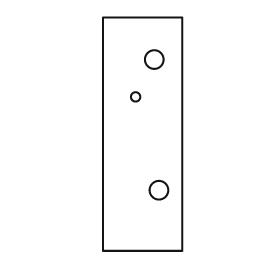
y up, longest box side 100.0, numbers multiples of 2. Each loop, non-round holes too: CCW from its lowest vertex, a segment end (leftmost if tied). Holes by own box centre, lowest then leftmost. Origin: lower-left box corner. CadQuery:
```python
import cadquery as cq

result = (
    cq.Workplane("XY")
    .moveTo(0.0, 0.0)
    .lineTo(34.0, 0.0)
    .lineTo(34.0, 100.0)
    .lineTo(0.0, 100.0)
    .close()
    .moveTo(24.0, 26.0)
    .circle(4.0)
    .moveTo(14.0, 66.0)
    .circle(2.0)
    .moveTo(22.0, 82.0)
    .circle(4.0)
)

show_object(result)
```